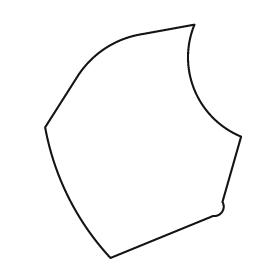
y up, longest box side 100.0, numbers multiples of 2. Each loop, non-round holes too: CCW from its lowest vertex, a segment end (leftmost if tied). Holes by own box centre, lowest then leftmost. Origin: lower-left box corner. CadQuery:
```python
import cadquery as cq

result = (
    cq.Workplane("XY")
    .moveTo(28.0, 0.0)
    .lineTo(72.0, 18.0)
    .threePointArc((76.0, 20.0), (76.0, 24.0))
    .lineTo(84.0, 52.0)
    .threePointArc((64.0, 72.0), (64.0, 100.0))
    .lineTo(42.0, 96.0)
    .threePointArc((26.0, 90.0), (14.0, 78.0))
    .lineTo(0.0, 56.0)
    .threePointArc((10.0, 26.0), (28.0, 0.0))
    .close()
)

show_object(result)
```